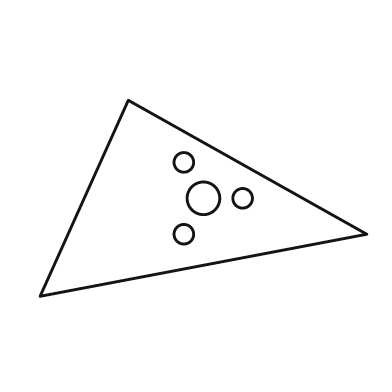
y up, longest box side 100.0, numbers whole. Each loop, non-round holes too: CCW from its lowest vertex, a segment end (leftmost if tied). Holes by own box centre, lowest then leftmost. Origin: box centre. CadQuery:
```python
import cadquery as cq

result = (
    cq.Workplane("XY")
    .moveTo(-50.0, -30.0)
    .lineTo(50.0, -11.0)
    .lineTo(-23.0, 30.0)
    .close()
    .moveTo(-6.0, -11.0)
    .circle(3.0)
    .moveTo(0.0, 0.0)
    .circle(5.0)
    .moveTo(12.0, 0.0)
    .circle(3.0)
    .moveTo(-6.0, 11.0)
    .circle(3.0)
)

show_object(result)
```